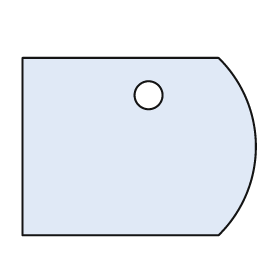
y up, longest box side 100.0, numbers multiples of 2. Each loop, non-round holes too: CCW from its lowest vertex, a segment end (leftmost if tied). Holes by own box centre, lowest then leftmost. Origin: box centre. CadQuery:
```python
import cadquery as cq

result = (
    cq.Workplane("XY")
    .moveTo(-50.0, -38.0)
    .lineTo(34.0, -38.0)
    .threePointArc((50.0, 0.0), (34.0, 38.0))
    .lineTo(-50.0, 38.0)
    .close()
    .moveTo(4.0, 22.0)
    .circle(6.0)
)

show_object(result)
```